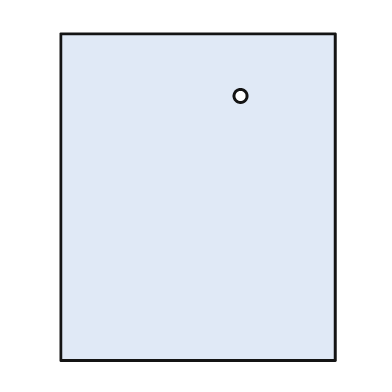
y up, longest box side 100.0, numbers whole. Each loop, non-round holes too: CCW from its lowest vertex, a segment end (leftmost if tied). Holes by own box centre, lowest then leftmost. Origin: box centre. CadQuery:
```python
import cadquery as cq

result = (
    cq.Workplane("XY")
    .moveTo(-42.0, -50.0)
    .lineTo(42.0, -50.0)
    .lineTo(42.0, 50.0)
    .lineTo(-42.0, 50.0)
    .close()
    .moveTo(13.0, 31.0)
    .circle(2.0)
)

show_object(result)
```